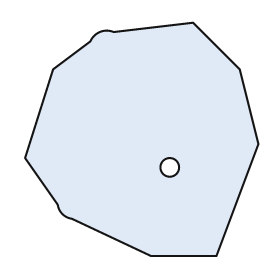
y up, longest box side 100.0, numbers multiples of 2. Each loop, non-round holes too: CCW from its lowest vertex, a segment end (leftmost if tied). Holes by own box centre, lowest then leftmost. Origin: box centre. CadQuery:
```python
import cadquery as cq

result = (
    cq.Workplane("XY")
    .moveTo(4.0, -50.0)
    .lineTo(32.0, -50.0)
    .lineTo(50.0, -2.0)
    .lineTo(42.0, 30.0)
    .lineTo(22.0, 50.0)
    .lineTo(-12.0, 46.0)
    .threePointArc((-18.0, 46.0), (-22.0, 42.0))
    .lineTo(-38.0, 30.0)
    .lineTo(-50.0, -8.0)
    .lineTo(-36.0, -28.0)
    .threePointArc((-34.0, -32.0), (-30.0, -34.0))
    .close()
    .moveTo(12.0, -12.0)
    .circle(4.0)
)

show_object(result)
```